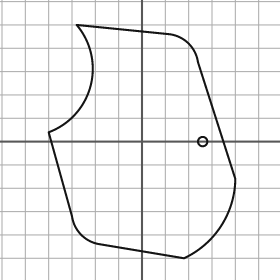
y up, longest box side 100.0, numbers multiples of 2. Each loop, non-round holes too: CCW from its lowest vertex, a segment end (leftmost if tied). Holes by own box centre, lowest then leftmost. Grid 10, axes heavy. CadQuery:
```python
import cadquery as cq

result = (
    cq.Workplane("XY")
    .moveTo(18.0, -50.0)
    .threePointArc((34.0, -36.0), (40.0, -16.0))
    .lineTo(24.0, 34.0)
    .threePointArc((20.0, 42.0), (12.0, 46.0))
    .lineTo(-28.0, 50.0)
    .threePointArc((-22.0, 24.0), (-40.0, 4.0))
    .lineTo(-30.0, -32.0)
    .threePointArc((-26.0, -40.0), (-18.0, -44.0))
    .close()
    .moveTo(26.0, 0.0)
    .circle(2.0)
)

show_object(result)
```